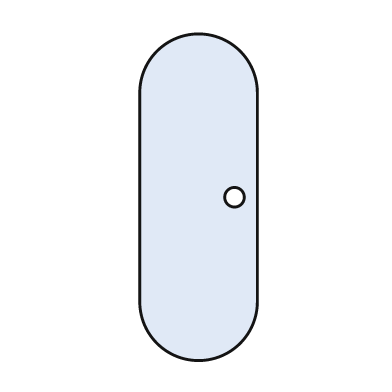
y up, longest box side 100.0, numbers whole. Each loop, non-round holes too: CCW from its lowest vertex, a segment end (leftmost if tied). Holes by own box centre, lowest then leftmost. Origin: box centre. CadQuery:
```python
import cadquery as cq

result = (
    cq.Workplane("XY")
    .moveTo(-18.0, -32.0)
    .threePointArc((0.0, -50.0), (18.0, -32.0))
    .lineTo(18.0, 32.0)
    .threePointArc((0.0, 50.0), (-18.0, 32.0))
    .close()
    .moveTo(11.0, 0.0)
    .circle(3.0)
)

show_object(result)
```